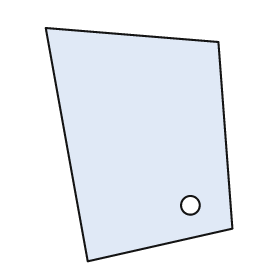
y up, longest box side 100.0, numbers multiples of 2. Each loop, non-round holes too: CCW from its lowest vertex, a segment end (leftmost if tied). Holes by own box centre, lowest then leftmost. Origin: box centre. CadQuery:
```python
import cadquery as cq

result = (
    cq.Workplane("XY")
    .moveTo(-22.0, -50.0)
    .lineTo(40.0, -36.0)
    .lineTo(34.0, 44.0)
    .lineTo(-40.0, 50.0)
    .close()
    .moveTo(22.0, -26.0)
    .circle(4.0)
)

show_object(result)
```